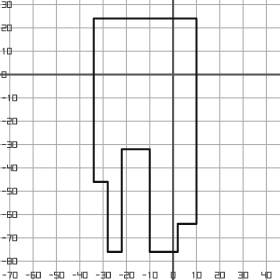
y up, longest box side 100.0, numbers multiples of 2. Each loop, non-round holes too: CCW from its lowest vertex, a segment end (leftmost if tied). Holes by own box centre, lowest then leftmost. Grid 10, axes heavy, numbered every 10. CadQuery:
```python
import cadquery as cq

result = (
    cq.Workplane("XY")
    .moveTo(-28.0, -76.0)
    .lineTo(-22.0, -76.0)
    .lineTo(-22.0, -32.0)
    .lineTo(-10.0, -32.0)
    .lineTo(-10.0, -76.0)
    .lineTo(2.0, -76.0)
    .lineTo(2.0, -64.0)
    .lineTo(10.0, -64.0)
    .lineTo(10.0, 24.0)
    .lineTo(-34.0, 24.0)
    .lineTo(-34.0, -46.0)
    .lineTo(-28.0, -46.0)
    .close()
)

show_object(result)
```